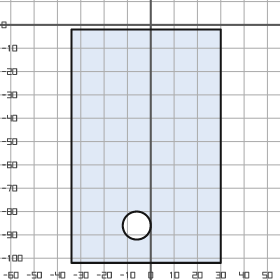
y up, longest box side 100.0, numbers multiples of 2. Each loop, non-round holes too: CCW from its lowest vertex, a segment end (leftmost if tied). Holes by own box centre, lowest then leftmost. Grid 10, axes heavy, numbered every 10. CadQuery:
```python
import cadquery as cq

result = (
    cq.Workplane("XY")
    .moveTo(-34.0, -102.0)
    .lineTo(30.0, -102.0)
    .lineTo(30.0, -2.0)
    .lineTo(-34.0, -2.0)
    .close()
    .moveTo(-6.0, -86.0)
    .circle(6.0)
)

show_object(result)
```